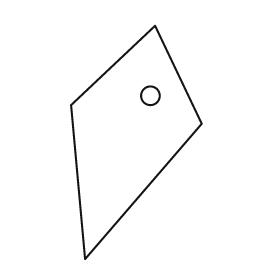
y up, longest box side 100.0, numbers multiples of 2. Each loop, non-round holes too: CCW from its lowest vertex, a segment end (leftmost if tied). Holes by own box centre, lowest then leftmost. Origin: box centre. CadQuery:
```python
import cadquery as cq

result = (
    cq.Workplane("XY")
    .moveTo(-22.0, -50.0)
    .lineTo(28.0, 8.0)
    .lineTo(8.0, 50.0)
    .lineTo(-28.0, 16.0)
    .close()
    .moveTo(6.0, 20.0)
    .circle(4.0)
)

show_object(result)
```